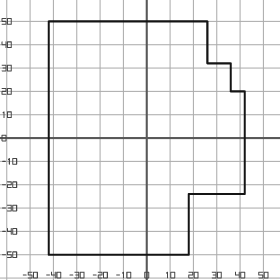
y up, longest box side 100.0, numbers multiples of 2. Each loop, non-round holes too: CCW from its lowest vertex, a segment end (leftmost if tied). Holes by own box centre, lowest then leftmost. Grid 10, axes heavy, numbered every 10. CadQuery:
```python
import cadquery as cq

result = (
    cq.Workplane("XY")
    .moveTo(-42.0, -50.0)
    .lineTo(18.0, -50.0)
    .lineTo(18.0, -24.0)
    .lineTo(42.0, -24.0)
    .lineTo(42.0, 20.0)
    .lineTo(36.0, 20.0)
    .lineTo(36.0, 32.0)
    .lineTo(26.0, 32.0)
    .lineTo(26.0, 50.0)
    .lineTo(-42.0, 50.0)
    .close()
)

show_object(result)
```